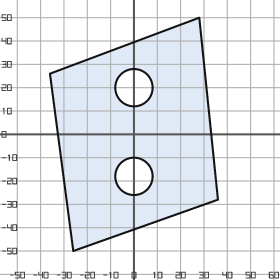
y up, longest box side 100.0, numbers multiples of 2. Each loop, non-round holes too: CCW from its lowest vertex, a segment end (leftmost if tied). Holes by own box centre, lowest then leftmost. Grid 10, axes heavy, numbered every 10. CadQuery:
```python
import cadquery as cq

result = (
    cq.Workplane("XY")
    .moveTo(-26.0, -50.0)
    .lineTo(36.0, -28.0)
    .lineTo(28.0, 50.0)
    .lineTo(-36.0, 26.0)
    .close()
    .moveTo(0.0, -18.0)
    .circle(8.0)
    .moveTo(0.0, 20.0)
    .circle(8.0)
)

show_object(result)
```